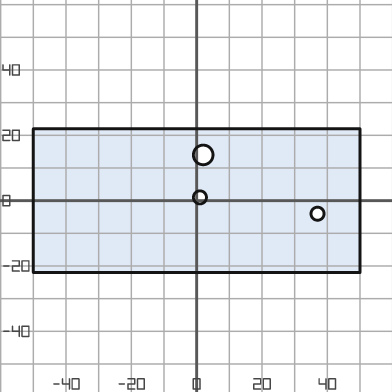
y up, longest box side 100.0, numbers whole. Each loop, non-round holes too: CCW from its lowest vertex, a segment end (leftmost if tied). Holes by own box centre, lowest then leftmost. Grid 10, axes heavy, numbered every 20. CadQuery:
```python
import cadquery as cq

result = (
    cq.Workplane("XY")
    .moveTo(-50.0, -22.0)
    .lineTo(50.0, -22.0)
    .lineTo(50.0, 22.0)
    .lineTo(-50.0, 22.0)
    .close()
    .moveTo(37.0, -4.0)
    .circle(2.0)
    .moveTo(1.0, 1.0)
    .circle(2.0)
    .moveTo(2.0, 14.0)
    .circle(3.0)
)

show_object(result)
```